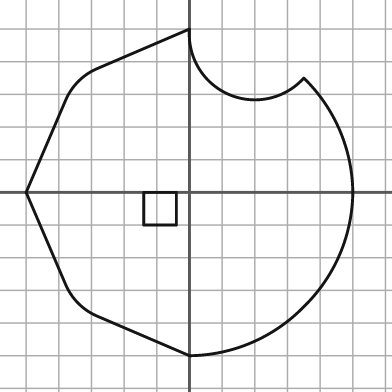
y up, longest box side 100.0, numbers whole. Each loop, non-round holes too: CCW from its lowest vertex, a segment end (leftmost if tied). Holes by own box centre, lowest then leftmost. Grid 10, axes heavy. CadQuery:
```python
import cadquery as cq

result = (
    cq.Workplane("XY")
    .moveTo(0.0, -50.0)
    .threePointArc((19.0, -46.0), (35.0, -35.0))
    .threePointArc((46.0, -19.0), (50.0, 0.0))
    .threePointArc((46.0, 19.0), (35.0, 35.0))
    .threePointArc((12.0, 30.0), (0.0, 50.0))
    .lineTo(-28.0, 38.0)
    .threePointArc((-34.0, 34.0), (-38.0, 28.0))
    .lineTo(-50.0, 0.0)
    .lineTo(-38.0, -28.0)
    .threePointArc((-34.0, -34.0), (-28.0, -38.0))
    .close()
    .moveTo(-14.0, -10.0)
    .lineTo(-4.0, -10.0)
    .lineTo(-4.0, 0.0)
    .lineTo(-14.0, 0.0)
    .close()
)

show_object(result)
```